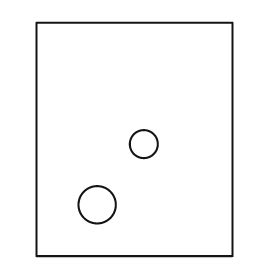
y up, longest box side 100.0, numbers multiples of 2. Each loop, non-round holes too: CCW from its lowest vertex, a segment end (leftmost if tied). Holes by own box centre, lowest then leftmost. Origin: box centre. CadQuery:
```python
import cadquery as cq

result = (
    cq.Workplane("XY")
    .moveTo(-42.0, -50.0)
    .lineTo(42.0, -50.0)
    .lineTo(42.0, 50.0)
    .lineTo(-42.0, 50.0)
    .close()
    .moveTo(-16.0, -28.0)
    .circle(8.0)
    .moveTo(4.0, -2.0)
    .circle(6.0)
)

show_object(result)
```